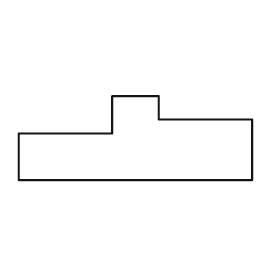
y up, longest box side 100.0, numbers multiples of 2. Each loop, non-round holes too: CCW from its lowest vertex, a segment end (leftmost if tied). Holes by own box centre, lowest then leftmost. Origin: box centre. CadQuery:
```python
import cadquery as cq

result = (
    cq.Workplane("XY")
    .moveTo(-50.0, -18.0)
    .lineTo(50.0, -18.0)
    .lineTo(50.0, 8.0)
    .lineTo(10.0, 8.0)
    .lineTo(10.0, 18.0)
    .lineTo(-10.0, 18.0)
    .lineTo(-10.0, 2.0)
    .lineTo(-50.0, 2.0)
    .close()
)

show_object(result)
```